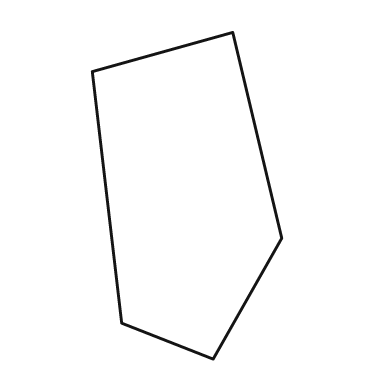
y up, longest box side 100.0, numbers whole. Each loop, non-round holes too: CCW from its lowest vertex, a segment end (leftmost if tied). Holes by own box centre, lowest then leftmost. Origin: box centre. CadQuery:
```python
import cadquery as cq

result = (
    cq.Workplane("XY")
    .moveTo(8.0, -50.0)
    .lineTo(29.0, -13.0)
    .lineTo(14.0, 50.0)
    .lineTo(-29.0, 38.0)
    .lineTo(-20.0, -39.0)
    .close()
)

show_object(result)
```